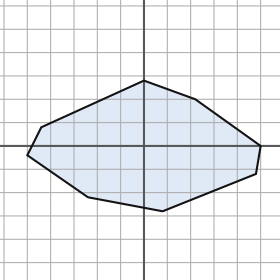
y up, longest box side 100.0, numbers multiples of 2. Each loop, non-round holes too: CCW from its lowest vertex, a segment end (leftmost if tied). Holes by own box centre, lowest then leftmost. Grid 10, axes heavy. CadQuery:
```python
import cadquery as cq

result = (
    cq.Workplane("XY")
    .moveTo(8.0, -28.0)
    .lineTo(48.0, -12.0)
    .lineTo(50.0, 0.0)
    .lineTo(22.0, 20.0)
    .lineTo(0.0, 28.0)
    .lineTo(-44.0, 8.0)
    .lineTo(-50.0, -4.0)
    .lineTo(-24.0, -22.0)
    .close()
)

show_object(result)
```